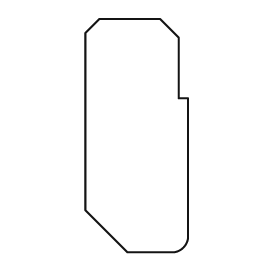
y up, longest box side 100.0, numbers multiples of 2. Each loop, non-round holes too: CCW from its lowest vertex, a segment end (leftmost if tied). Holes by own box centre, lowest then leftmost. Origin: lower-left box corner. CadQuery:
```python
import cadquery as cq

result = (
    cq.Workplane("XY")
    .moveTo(18.0, 0.0)
    .lineTo(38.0, 0.0)
    .threePointArc((42.0, 2.0), (44.0, 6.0))
    .lineTo(44.0, 66.0)
    .lineTo(40.0, 66.0)
    .lineTo(40.0, 92.0)
    .lineTo(32.0, 100.0)
    .lineTo(6.0, 100.0)
    .lineTo(0.0, 94.0)
    .lineTo(0.0, 18.0)
    .close()
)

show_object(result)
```